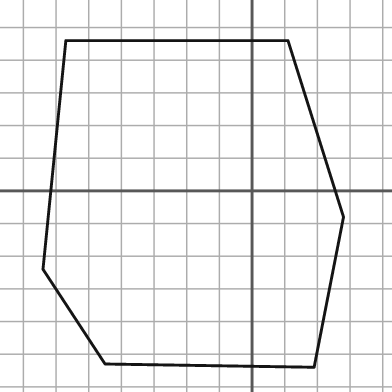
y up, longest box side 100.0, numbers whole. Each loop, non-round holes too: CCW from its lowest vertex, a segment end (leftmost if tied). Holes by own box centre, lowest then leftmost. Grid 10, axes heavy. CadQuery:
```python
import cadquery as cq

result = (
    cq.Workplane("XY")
    .moveTo(19.0, -54.0)
    .lineTo(28.0, -8.0)
    .lineTo(11.0, 46.0)
    .lineTo(-57.0, 46.0)
    .lineTo(-64.0, -24.0)
    .lineTo(-45.0, -53.0)
    .close()
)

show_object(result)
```